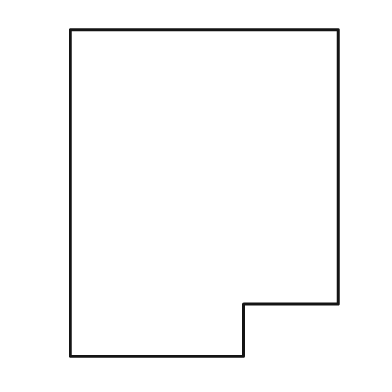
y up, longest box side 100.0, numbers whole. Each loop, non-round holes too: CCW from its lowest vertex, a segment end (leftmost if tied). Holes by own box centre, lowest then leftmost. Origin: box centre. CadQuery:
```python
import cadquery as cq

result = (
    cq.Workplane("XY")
    .moveTo(-41.0, -50.0)
    .lineTo(12.0, -50.0)
    .lineTo(12.0, -34.0)
    .lineTo(41.0, -34.0)
    .lineTo(41.0, 50.0)
    .lineTo(-41.0, 50.0)
    .close()
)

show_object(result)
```